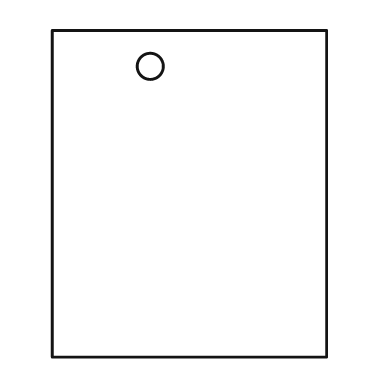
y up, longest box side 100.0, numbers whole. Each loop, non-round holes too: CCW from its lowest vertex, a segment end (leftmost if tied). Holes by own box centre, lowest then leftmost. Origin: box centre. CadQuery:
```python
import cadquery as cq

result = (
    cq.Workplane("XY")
    .moveTo(-42.0, -50.0)
    .lineTo(42.0, -50.0)
    .lineTo(42.0, 50.0)
    .lineTo(-42.0, 50.0)
    .close()
    .moveTo(-12.0, 39.0)
    .circle(4.0)
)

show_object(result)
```